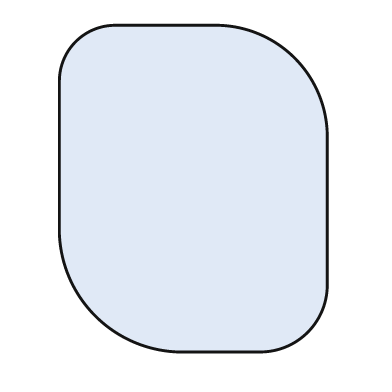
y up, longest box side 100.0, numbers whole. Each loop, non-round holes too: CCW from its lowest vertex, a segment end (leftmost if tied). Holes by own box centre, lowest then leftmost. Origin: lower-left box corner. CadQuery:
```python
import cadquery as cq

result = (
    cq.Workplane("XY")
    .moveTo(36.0, 0.0)
    .lineTo(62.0, 0.0)
    .threePointArc((76.0, 6.0), (82.0, 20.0))
    .lineTo(82.0, 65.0)
    .threePointArc((72.0, 90.0), (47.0, 100.0))
    .lineTo(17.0, 100.0)
    .threePointArc((5.0, 95.0), (0.0, 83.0))
    .lineTo(0.0, 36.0)
    .threePointArc((11.0, 11.0), (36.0, 0.0))
    .close()
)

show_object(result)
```